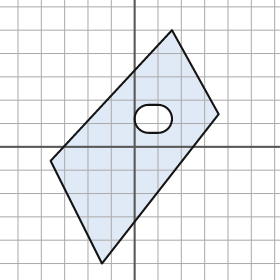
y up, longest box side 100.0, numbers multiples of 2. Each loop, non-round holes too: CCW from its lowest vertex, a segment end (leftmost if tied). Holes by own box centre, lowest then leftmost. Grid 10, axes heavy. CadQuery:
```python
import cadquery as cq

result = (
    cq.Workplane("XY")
    .moveTo(-14.0, -50.0)
    .lineTo(36.0, 14.0)
    .lineTo(16.0, 50.0)
    .lineTo(-36.0, -6.0)
    .close()
    .moveTo(6.0, 6.0)
    .lineTo(10.0, 6.0)
    .threePointArc((16.0, 12.0), (10.0, 18.0))
    .lineTo(6.0, 18.0)
    .threePointArc((0.0, 12.0), (6.0, 6.0))
    .close()
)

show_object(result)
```